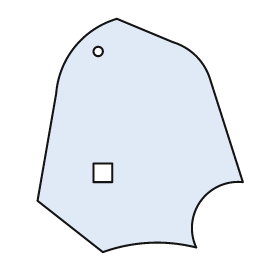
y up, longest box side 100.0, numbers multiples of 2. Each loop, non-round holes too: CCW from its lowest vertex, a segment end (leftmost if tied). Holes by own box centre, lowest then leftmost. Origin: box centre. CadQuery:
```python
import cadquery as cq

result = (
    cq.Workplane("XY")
    .moveTo(-16.0, -50.0)
    .threePointArc((4.0, -46.0), (24.0, -48.0))
    .threePointArc((26.0, -28.0), (44.0, -20.0))
    .lineTo(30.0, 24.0)
    .threePointArc((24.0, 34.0), (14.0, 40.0))
    .lineTo(-10.0, 50.0)
    .threePointArc((-28.0, 38.0), (-36.0, 18.0))
    .lineTo(-44.0, -28.0)
    .close()
    .moveTo(-20.0, -20.0)
    .lineTo(-12.0, -20.0)
    .lineTo(-12.0, -12.0)
    .lineTo(-20.0, -12.0)
    .close()
    .moveTo(-18.0, 36.0)
    .circle(2.0)
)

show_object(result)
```